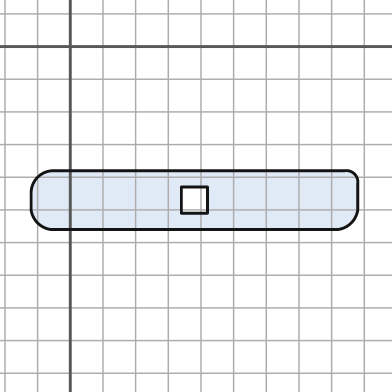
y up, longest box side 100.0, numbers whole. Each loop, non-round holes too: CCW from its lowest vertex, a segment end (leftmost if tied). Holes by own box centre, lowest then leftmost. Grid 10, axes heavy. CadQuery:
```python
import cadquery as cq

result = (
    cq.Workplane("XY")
    .moveTo(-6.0, -56.0)
    .lineTo(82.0, -56.0)
    .threePointArc((86.0, -54.0), (88.0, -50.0))
    .lineTo(88.0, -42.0)
    .threePointArc((87.0, -39.0), (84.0, -38.0))
    .lineTo(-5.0, -38.0)
    .threePointArc((-10.0, -40.0), (-12.0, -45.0))
    .lineTo(-12.0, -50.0)
    .threePointArc((-10.0, -54.0), (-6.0, -56.0))
    .close()
    .moveTo(34.0, -51.0)
    .lineTo(42.0, -51.0)
    .lineTo(42.0, -43.0)
    .lineTo(34.0, -43.0)
    .close()
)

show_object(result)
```